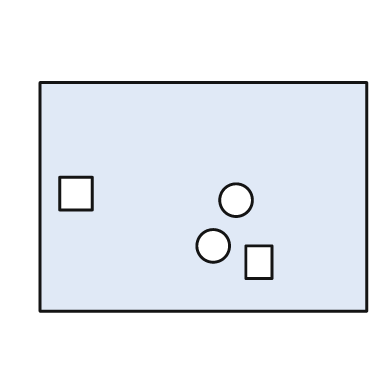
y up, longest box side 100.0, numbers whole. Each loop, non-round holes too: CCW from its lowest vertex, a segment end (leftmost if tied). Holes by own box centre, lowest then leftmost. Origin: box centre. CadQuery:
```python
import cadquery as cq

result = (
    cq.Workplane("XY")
    .moveTo(-50.0, -35.0)
    .lineTo(50.0, -35.0)
    .lineTo(50.0, 35.0)
    .lineTo(-50.0, 35.0)
    .close()
    .moveTo(13.0, -25.0)
    .lineTo(21.0, -25.0)
    .lineTo(21.0, -15.0)
    .lineTo(13.0, -15.0)
    .close()
    .moveTo(3.0, -15.0)
    .circle(5.0)
    .moveTo(10.0, -1.0)
    .circle(5.0)
    .moveTo(-44.0, -4.0)
    .lineTo(-34.0, -4.0)
    .lineTo(-34.0, 6.0)
    .lineTo(-44.0, 6.0)
    .close()
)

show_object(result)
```